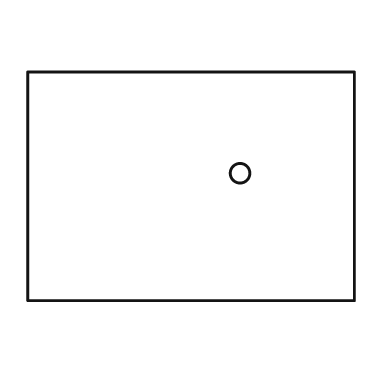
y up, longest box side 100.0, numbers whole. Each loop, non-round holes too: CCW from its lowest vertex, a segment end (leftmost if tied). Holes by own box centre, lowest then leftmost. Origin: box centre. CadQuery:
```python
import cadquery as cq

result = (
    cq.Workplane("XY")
    .moveTo(-50.0, -35.0)
    .lineTo(50.0, -35.0)
    .lineTo(50.0, 35.0)
    .lineTo(-50.0, 35.0)
    .close()
    .moveTo(15.0, 4.0)
    .circle(3.0)
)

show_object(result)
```